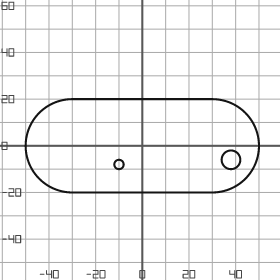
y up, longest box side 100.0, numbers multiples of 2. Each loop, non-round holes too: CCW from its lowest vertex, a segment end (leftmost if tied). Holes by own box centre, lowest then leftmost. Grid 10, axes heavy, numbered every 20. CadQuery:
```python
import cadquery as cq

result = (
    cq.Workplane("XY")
    .moveTo(-30.0, -20.0)
    .lineTo(30.0, -20.0)
    .threePointArc((50.0, 0.0), (30.0, 20.0))
    .lineTo(-30.0, 20.0)
    .threePointArc((-50.0, 0.0), (-30.0, -20.0))
    .close()
    .moveTo(-10.0, -8.0)
    .circle(2.0)
    .moveTo(38.0, -6.0)
    .circle(4.0)
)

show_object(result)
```